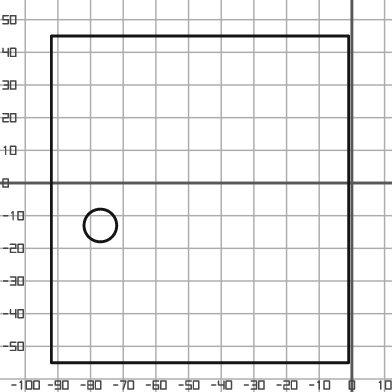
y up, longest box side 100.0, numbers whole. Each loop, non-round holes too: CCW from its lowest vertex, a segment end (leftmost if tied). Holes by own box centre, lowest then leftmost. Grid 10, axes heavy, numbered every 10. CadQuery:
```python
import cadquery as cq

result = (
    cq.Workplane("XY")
    .moveTo(-92.0, -55.0)
    .lineTo(-1.0, -55.0)
    .lineTo(-1.0, 45.0)
    .lineTo(-92.0, 45.0)
    .close()
    .moveTo(-77.0, -13.0)
    .circle(5.0)
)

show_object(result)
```